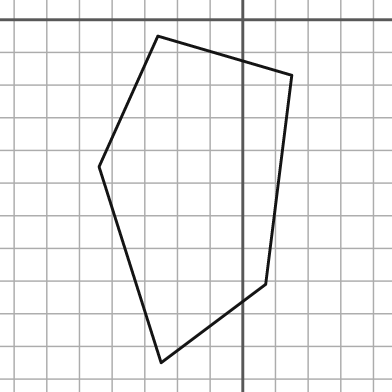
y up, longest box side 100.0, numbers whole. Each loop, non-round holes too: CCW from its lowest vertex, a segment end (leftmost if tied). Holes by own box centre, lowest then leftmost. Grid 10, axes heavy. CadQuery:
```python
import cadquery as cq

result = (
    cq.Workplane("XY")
    .moveTo(-25.0, -105.0)
    .lineTo(7.0, -81.0)
    .lineTo(15.0, -17.0)
    .lineTo(-26.0, -5.0)
    .lineTo(-44.0, -45.0)
    .close()
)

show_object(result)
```